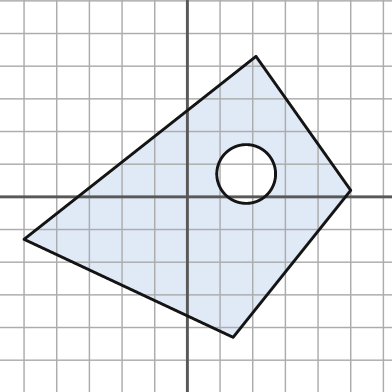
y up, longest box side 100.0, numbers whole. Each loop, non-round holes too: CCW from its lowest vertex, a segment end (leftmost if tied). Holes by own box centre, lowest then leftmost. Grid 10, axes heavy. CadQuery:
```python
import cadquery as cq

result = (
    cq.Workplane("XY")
    .moveTo(14.0, -43.0)
    .lineTo(50.0, 2.0)
    .lineTo(21.0, 43.0)
    .lineTo(-50.0, -13.0)
    .close()
    .moveTo(18.0, 7.0)
    .circle(9.0)
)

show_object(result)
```